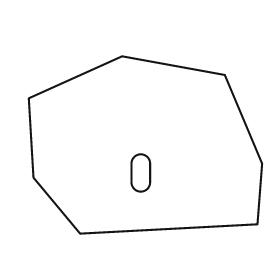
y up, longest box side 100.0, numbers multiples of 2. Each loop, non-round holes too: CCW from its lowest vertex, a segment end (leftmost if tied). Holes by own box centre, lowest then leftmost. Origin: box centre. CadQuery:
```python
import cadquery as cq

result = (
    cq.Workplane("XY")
    .moveTo(-28.0, -38.0)
    .lineTo(48.0, -34.0)
    .lineTo(50.0, -8.0)
    .lineTo(34.0, 30.0)
    .lineTo(-10.0, 38.0)
    .lineTo(-50.0, 20.0)
    .lineTo(-48.0, -14.0)
    .close()
    .moveTo(-6.0, -16.0)
    .threePointArc((-2.0, -20.0), (2.0, -16.0))
    .lineTo(2.0, -8.0)
    .threePointArc((-2.0, -4.0), (-6.0, -8.0))
    .close()
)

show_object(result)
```